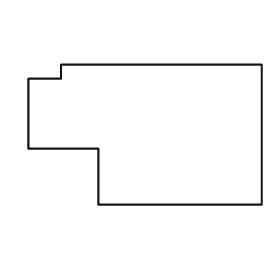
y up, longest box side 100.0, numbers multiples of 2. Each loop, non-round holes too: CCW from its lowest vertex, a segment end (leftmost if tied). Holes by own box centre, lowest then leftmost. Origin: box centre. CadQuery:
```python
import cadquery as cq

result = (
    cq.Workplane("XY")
    .moveTo(-20.0, -30.0)
    .lineTo(50.0, -30.0)
    .lineTo(50.0, 30.0)
    .lineTo(-36.0, 30.0)
    .lineTo(-36.0, 24.0)
    .lineTo(-50.0, 24.0)
    .lineTo(-50.0, -6.0)
    .lineTo(-20.0, -6.0)
    .close()
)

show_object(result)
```